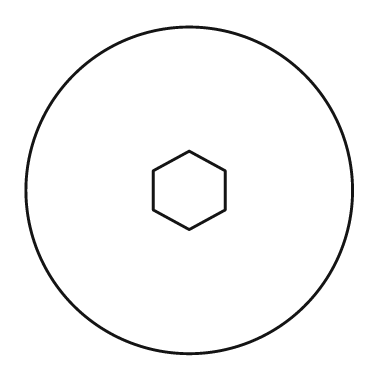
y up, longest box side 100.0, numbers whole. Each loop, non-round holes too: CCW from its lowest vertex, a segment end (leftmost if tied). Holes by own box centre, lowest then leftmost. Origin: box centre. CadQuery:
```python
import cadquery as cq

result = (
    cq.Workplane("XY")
    .moveTo(0.0, 0.0)
    .circle(50.0)
    .moveTo(0.0, -12.0)
    .lineTo(11.0, -6.0)
    .lineTo(11.0, 6.0)
    .lineTo(0.0, 12.0)
    .lineTo(-11.0, 6.0)
    .lineTo(-11.0, -6.0)
    .close()
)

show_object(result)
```